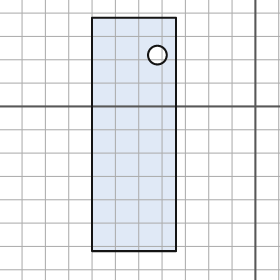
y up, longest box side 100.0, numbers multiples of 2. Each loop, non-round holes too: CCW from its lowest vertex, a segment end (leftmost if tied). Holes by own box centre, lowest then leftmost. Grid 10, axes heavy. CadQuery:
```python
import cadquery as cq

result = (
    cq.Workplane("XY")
    .moveTo(-70.0, -62.0)
    .lineTo(-34.0, -62.0)
    .lineTo(-34.0, 38.0)
    .lineTo(-70.0, 38.0)
    .close()
    .moveTo(-42.0, 22.0)
    .circle(4.0)
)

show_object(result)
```